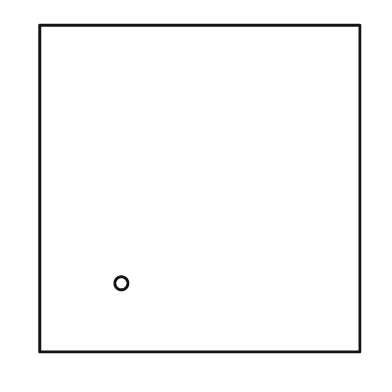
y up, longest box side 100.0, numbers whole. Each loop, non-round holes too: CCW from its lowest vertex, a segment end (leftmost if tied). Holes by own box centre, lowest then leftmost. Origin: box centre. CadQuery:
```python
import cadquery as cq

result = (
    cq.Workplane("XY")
    .moveTo(-49.0, -50.0)
    .lineTo(49.0, -50.0)
    .lineTo(49.0, 50.0)
    .lineTo(-49.0, 50.0)
    .close()
    .moveTo(-24.0, -29.0)
    .circle(2.0)
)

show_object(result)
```